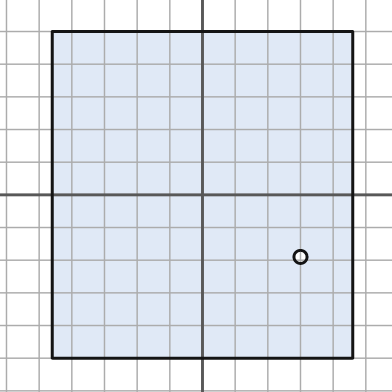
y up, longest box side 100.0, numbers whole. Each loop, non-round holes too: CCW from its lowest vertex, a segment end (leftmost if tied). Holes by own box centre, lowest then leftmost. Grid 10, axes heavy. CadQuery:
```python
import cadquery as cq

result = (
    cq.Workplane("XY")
    .moveTo(-46.0, -50.0)
    .lineTo(46.0, -50.0)
    .lineTo(46.0, 50.0)
    .lineTo(-46.0, 50.0)
    .close()
    .moveTo(30.0, -19.0)
    .circle(2.0)
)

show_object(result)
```